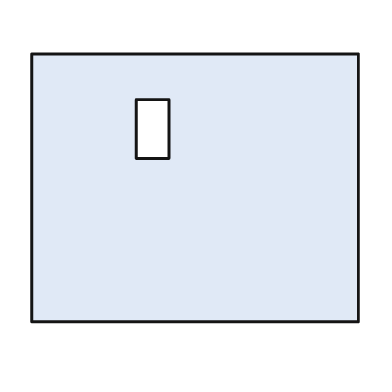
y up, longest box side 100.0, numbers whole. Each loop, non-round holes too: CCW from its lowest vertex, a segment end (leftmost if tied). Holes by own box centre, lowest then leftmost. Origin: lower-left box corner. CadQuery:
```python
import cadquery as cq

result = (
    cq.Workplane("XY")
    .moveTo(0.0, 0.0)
    .lineTo(100.0, 0.0)
    .lineTo(100.0, 82.0)
    .lineTo(0.0, 82.0)
    .close()
    .moveTo(32.0, 50.0)
    .lineTo(42.0, 50.0)
    .lineTo(42.0, 68.0)
    .lineTo(32.0, 68.0)
    .close()
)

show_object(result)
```